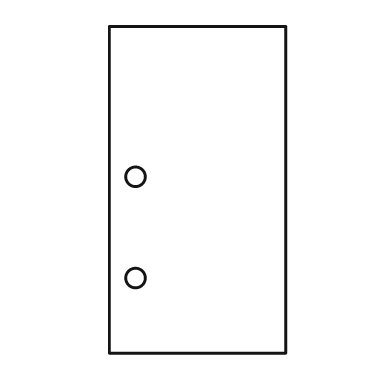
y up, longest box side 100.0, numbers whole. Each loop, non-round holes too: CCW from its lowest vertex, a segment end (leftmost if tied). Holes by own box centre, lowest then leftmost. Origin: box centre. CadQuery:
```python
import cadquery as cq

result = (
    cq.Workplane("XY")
    .moveTo(-27.0, -50.0)
    .lineTo(27.0, -50.0)
    .lineTo(27.0, 50.0)
    .lineTo(-27.0, 50.0)
    .close()
    .moveTo(-19.0, -27.0)
    .circle(3.0)
    .moveTo(-19.0, 4.0)
    .circle(3.0)
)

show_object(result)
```